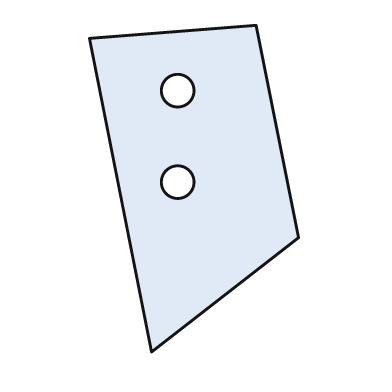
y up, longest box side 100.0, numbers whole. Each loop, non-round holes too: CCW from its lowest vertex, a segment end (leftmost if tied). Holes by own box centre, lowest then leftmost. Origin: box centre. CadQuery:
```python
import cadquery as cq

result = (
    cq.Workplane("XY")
    .moveTo(-13.0, -50.0)
    .lineTo(32.0, -15.0)
    .lineTo(19.0, 50.0)
    .lineTo(-32.0, 46.0)
    .close()
    .moveTo(-5.0, 2.0)
    .circle(5.0)
    .moveTo(-5.0, 30.0)
    .circle(5.0)
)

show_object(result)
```